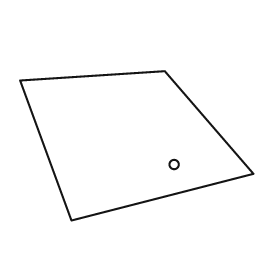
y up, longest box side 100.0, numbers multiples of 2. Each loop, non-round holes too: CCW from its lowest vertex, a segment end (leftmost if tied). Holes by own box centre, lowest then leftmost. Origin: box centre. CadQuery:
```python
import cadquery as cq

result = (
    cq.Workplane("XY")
    .moveTo(-28.0, -32.0)
    .lineTo(50.0, -12.0)
    .lineTo(12.0, 32.0)
    .lineTo(-50.0, 28.0)
    .close()
    .moveTo(16.0, -8.0)
    .circle(2.0)
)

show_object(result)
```